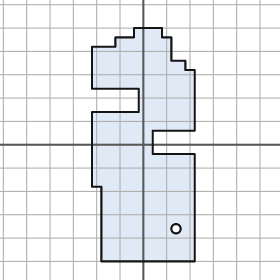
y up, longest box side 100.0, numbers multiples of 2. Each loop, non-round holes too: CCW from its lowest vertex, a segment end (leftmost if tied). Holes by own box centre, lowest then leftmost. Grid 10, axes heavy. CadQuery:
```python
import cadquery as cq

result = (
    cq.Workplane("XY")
    .moveTo(-18.0, -50.0)
    .lineTo(22.0, -50.0)
    .lineTo(22.0, -4.0)
    .lineTo(4.0, -4.0)
    .lineTo(4.0, 6.0)
    .lineTo(22.0, 6.0)
    .lineTo(22.0, 32.0)
    .lineTo(18.0, 32.0)
    .lineTo(18.0, 36.0)
    .lineTo(12.0, 36.0)
    .lineTo(12.0, 46.0)
    .lineTo(8.0, 46.0)
    .lineTo(8.0, 50.0)
    .lineTo(-4.0, 50.0)
    .lineTo(-4.0, 46.0)
    .lineTo(-12.0, 46.0)
    .lineTo(-12.0, 42.0)
    .lineTo(-22.0, 42.0)
    .lineTo(-22.0, 24.0)
    .lineTo(-2.0, 24.0)
    .lineTo(-2.0, 14.0)
    .lineTo(-22.0, 14.0)
    .lineTo(-22.0, -18.0)
    .lineTo(-18.0, -18.0)
    .close()
    .moveTo(14.0, -36.0)
    .circle(2.0)
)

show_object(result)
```